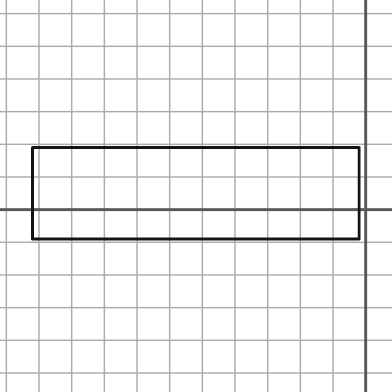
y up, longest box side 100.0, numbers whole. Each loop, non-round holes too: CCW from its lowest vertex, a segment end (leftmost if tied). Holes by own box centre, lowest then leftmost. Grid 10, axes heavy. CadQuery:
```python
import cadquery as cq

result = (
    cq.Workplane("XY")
    .moveTo(-102.0, -9.0)
    .lineTo(-2.0, -9.0)
    .lineTo(-2.0, 19.0)
    .lineTo(-102.0, 19.0)
    .close()
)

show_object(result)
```